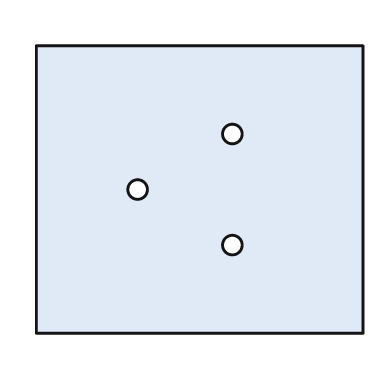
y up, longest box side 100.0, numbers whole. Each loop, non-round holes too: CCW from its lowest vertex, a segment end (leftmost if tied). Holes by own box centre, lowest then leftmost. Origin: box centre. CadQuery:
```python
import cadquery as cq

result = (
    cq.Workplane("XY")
    .moveTo(-50.0, -44.0)
    .lineTo(50.0, -44.0)
    .lineTo(50.0, 44.0)
    .lineTo(-50.0, 44.0)
    .close()
    .moveTo(10.0, -17.0)
    .circle(3.0)
    .moveTo(-19.0, 0.0)
    .circle(3.0)
    .moveTo(10.0, 17.0)
    .circle(3.0)
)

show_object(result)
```